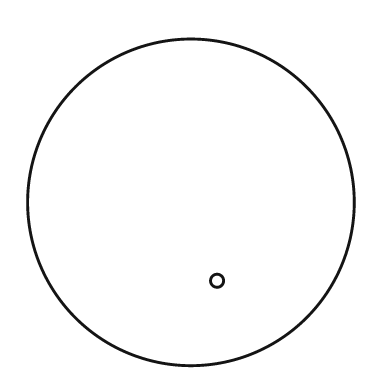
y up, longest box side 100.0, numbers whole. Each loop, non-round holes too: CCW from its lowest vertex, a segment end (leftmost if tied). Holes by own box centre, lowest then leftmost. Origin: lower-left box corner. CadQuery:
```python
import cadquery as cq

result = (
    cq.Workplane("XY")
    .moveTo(50.0, 50.0)
    .circle(50.0)
    .moveTo(58.0, 26.0)
    .circle(2.0)
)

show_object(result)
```